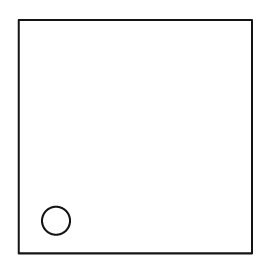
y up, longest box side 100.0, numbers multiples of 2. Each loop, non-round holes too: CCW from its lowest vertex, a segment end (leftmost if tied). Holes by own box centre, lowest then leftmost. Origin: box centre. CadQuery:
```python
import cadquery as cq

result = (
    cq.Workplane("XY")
    .moveTo(-50.0, -50.0)
    .lineTo(50.0, -50.0)
    .lineTo(50.0, 50.0)
    .lineTo(-50.0, 50.0)
    .close()
    .moveTo(-34.0, -36.0)
    .circle(6.0)
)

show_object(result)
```